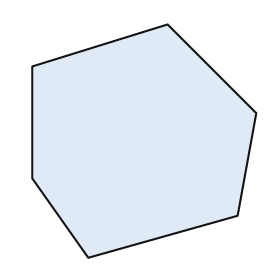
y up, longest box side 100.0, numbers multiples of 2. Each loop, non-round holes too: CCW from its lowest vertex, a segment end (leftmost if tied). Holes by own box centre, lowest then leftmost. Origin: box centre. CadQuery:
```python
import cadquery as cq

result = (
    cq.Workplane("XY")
    .moveTo(-24.0, -50.0)
    .lineTo(40.0, -32.0)
    .lineTo(48.0, 12.0)
    .lineTo(10.0, 50.0)
    .lineTo(-48.0, 32.0)
    .lineTo(-48.0, -16.0)
    .close()
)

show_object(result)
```